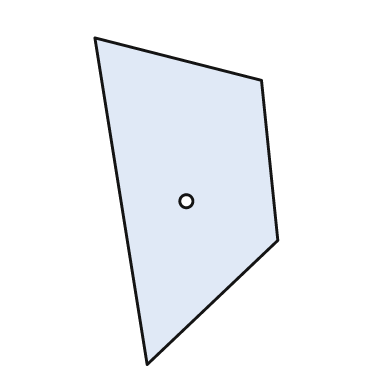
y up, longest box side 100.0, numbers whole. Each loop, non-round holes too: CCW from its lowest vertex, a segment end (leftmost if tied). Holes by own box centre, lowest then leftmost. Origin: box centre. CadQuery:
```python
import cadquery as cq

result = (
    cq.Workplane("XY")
    .moveTo(-12.0, -50.0)
    .lineTo(28.0, -12.0)
    .lineTo(23.0, 37.0)
    .lineTo(-28.0, 50.0)
    .close()
    .moveTo(0.0, 0.0)
    .circle(2.0)
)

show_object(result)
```